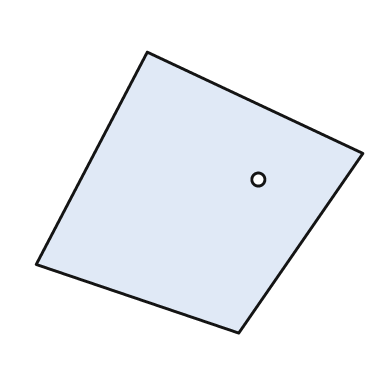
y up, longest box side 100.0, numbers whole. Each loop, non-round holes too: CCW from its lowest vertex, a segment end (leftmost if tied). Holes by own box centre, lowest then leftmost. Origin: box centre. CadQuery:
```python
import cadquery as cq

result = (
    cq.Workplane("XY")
    .moveTo(12.0, -43.0)
    .lineTo(50.0, 12.0)
    .lineTo(-16.0, 43.0)
    .lineTo(-50.0, -22.0)
    .close()
    .moveTo(18.0, 4.0)
    .circle(2.0)
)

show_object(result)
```